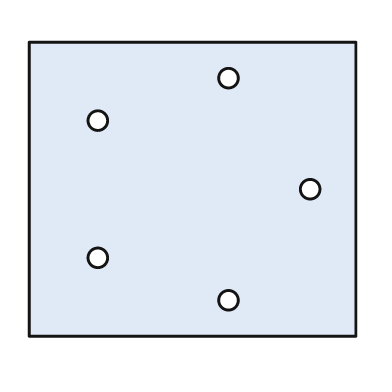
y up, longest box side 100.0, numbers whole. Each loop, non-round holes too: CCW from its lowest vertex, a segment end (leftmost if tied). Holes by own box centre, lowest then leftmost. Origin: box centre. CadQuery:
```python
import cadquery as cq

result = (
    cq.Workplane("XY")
    .moveTo(-50.0, -45.0)
    .lineTo(50.0, -45.0)
    .lineTo(50.0, 45.0)
    .lineTo(-50.0, 45.0)
    .close()
    .moveTo(11.0, -34.0)
    .circle(3.0)
    .moveTo(-29.0, -21.0)
    .circle(3.0)
    .moveTo(36.0, 0.0)
    .circle(3.0)
    .moveTo(-29.0, 21.0)
    .circle(3.0)
    .moveTo(11.0, 34.0)
    .circle(3.0)
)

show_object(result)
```